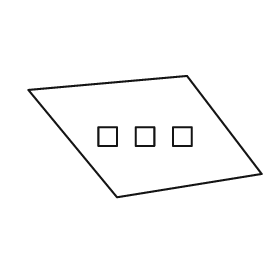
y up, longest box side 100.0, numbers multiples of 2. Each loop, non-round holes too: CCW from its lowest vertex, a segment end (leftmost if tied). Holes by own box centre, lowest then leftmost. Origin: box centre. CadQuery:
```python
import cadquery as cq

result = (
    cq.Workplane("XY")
    .moveTo(-12.0, -26.0)
    .lineTo(50.0, -16.0)
    .lineTo(18.0, 26.0)
    .lineTo(-50.0, 20.0)
    .close()
    .moveTo(-20.0, -4.0)
    .lineTo(-12.0, -4.0)
    .lineTo(-12.0, 4.0)
    .lineTo(-20.0, 4.0)
    .close()
    .moveTo(-4.0, -4.0)
    .lineTo(4.0, -4.0)
    .lineTo(4.0, 4.0)
    .lineTo(-4.0, 4.0)
    .close()
    .moveTo(12.0, -4.0)
    .lineTo(20.0, -4.0)
    .lineTo(20.0, 4.0)
    .lineTo(12.0, 4.0)
    .close()
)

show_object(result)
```